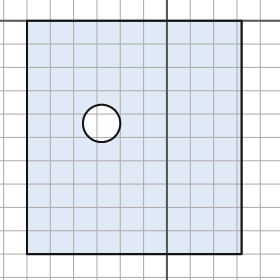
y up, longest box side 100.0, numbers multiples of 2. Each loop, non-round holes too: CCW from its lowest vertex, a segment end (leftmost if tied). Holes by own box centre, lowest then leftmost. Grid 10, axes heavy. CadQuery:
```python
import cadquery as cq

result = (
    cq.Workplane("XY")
    .moveTo(-60.0, -100.0)
    .lineTo(32.0, -100.0)
    .lineTo(32.0, 0.0)
    .lineTo(-60.0, 0.0)
    .close()
    .moveTo(-28.0, -44.0)
    .circle(8.0)
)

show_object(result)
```